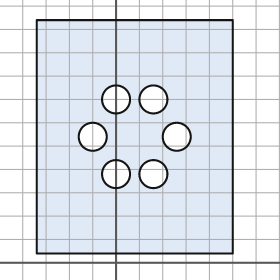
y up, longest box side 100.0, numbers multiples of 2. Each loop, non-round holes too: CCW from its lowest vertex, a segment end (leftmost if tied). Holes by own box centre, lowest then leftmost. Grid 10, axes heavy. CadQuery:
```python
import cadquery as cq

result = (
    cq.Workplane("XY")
    .moveTo(-34.0, 4.0)
    .lineTo(50.0, 4.0)
    .lineTo(50.0, 104.0)
    .lineTo(-34.0, 104.0)
    .close()
    .moveTo(0.0, 38.0)
    .circle(6.0)
    .moveTo(16.0, 38.0)
    .circle(6.0)
    .moveTo(-10.0, 54.0)
    .circle(6.0)
    .moveTo(26.0, 54.0)
    .circle(6.0)
    .moveTo(0.0, 70.0)
    .circle(6.0)
    .moveTo(16.0, 70.0)
    .circle(6.0)
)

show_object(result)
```